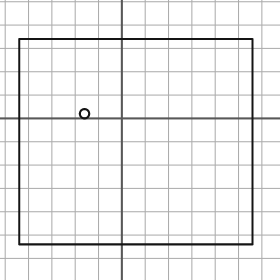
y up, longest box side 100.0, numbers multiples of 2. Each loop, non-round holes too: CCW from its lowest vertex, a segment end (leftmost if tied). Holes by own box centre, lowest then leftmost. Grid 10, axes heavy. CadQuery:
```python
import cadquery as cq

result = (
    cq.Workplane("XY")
    .moveTo(-44.0, -54.0)
    .lineTo(56.0, -54.0)
    .lineTo(56.0, 34.0)
    .lineTo(-44.0, 34.0)
    .close()
    .moveTo(-16.0, 2.0)
    .circle(2.0)
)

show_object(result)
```